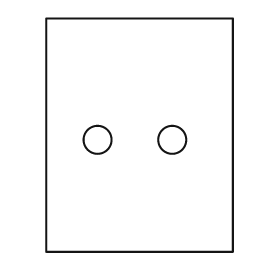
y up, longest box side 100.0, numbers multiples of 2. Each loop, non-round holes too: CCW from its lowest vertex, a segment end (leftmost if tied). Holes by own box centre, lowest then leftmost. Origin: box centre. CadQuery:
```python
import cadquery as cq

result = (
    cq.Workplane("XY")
    .moveTo(-40.0, -50.0)
    .lineTo(40.0, -50.0)
    .lineTo(40.0, 50.0)
    .lineTo(-40.0, 50.0)
    .close()
    .moveTo(-18.0, -2.0)
    .circle(6.0)
    .moveTo(14.0, -2.0)
    .circle(6.0)
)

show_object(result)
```